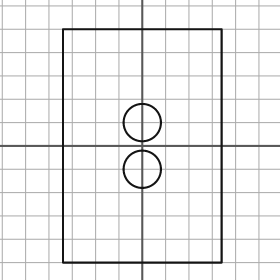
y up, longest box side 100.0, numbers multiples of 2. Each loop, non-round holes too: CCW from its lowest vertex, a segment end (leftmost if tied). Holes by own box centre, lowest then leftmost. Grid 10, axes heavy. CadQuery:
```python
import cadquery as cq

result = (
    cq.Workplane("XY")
    .moveTo(-34.0, -50.0)
    .lineTo(34.0, -50.0)
    .lineTo(34.0, 50.0)
    .lineTo(-34.0, 50.0)
    .close()
    .moveTo(0.0, -10.0)
    .circle(8.0)
    .moveTo(0.0, 10.0)
    .circle(8.0)
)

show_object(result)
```